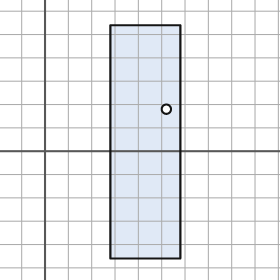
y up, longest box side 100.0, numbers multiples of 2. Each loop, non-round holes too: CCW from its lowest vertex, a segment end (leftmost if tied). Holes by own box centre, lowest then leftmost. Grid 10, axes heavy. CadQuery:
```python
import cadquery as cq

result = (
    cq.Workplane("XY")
    .moveTo(28.0, -46.0)
    .lineTo(58.0, -46.0)
    .lineTo(58.0, 54.0)
    .lineTo(28.0, 54.0)
    .close()
    .moveTo(52.0, 18.0)
    .circle(2.0)
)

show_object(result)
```